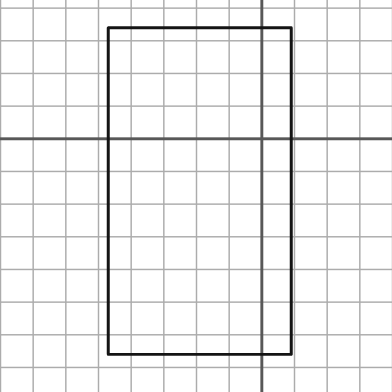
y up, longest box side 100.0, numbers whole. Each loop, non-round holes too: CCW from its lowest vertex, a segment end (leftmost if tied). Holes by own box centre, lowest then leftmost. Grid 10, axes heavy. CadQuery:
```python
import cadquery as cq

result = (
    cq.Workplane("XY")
    .moveTo(-47.0, -66.0)
    .lineTo(9.0, -66.0)
    .lineTo(9.0, 34.0)
    .lineTo(-47.0, 34.0)
    .close()
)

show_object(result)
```